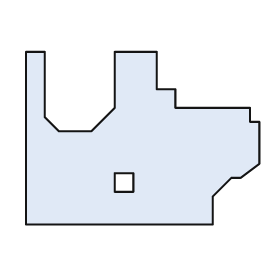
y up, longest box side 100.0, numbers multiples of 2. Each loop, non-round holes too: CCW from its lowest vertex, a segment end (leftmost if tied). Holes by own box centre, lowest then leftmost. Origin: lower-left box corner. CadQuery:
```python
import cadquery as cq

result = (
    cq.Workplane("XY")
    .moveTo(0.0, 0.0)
    .lineTo(80.0, 0.0)
    .lineTo(80.0, 12.0)
    .lineTo(88.0, 20.0)
    .lineTo(92.0, 20.0)
    .lineTo(100.0, 26.0)
    .lineTo(100.0, 44.0)
    .lineTo(96.0, 44.0)
    .lineTo(96.0, 50.0)
    .lineTo(64.0, 50.0)
    .lineTo(64.0, 58.0)
    .lineTo(56.0, 58.0)
    .lineTo(56.0, 74.0)
    .lineTo(38.0, 74.0)
    .lineTo(38.0, 50.0)
    .lineTo(28.0, 40.0)
    .lineTo(14.0, 40.0)
    .lineTo(8.0, 46.0)
    .lineTo(8.0, 74.0)
    .lineTo(0.0, 74.0)
    .close()
    .moveTo(38.0, 14.0)
    .lineTo(46.0, 14.0)
    .lineTo(46.0, 22.0)
    .lineTo(38.0, 22.0)
    .close()
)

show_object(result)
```